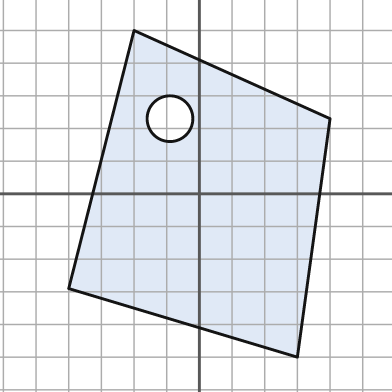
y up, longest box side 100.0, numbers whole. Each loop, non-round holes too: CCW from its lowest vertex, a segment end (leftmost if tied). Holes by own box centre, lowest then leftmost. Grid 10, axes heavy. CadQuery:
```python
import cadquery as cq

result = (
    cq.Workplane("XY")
    .moveTo(30.0, -50.0)
    .lineTo(40.0, 23.0)
    .lineTo(-20.0, 50.0)
    .lineTo(-40.0, -29.0)
    .close()
    .moveTo(-9.0, 23.0)
    .circle(7.0)
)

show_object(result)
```